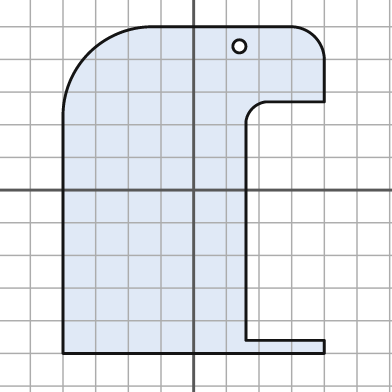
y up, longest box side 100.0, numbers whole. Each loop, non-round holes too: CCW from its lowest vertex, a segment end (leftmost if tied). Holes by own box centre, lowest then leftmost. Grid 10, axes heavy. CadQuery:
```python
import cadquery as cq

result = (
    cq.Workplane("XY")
    .moveTo(-40.0, -50.0)
    .lineTo(40.0, -50.0)
    .lineTo(40.0, -46.0)
    .lineTo(16.0, -46.0)
    .lineTo(16.0, 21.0)
    .threePointArc((18.0, 25.0), (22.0, 27.0))
    .lineTo(40.0, 27.0)
    .lineTo(40.0, 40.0)
    .threePointArc((37.0, 47.0), (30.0, 50.0))
    .lineTo(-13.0, 50.0)
    .threePointArc((-32.0, 42.0), (-40.0, 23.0))
    .close()
    .moveTo(14.0, 44.0)
    .circle(2.0)
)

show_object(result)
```